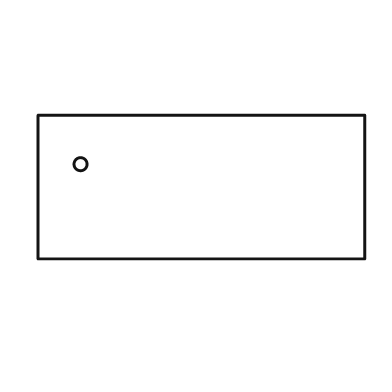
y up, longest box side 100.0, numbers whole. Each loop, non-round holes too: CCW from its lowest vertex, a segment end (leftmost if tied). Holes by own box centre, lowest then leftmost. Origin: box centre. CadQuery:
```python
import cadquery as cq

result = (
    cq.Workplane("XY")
    .moveTo(-50.0, -22.0)
    .lineTo(50.0, -22.0)
    .lineTo(50.0, 22.0)
    .lineTo(-50.0, 22.0)
    .close()
    .moveTo(-37.0, 7.0)
    .circle(2.0)
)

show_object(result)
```